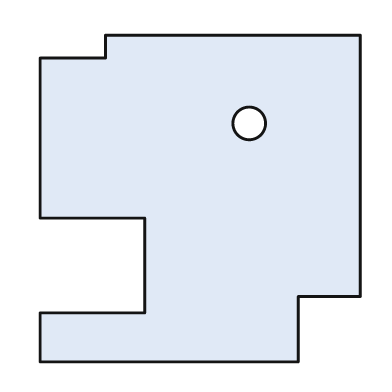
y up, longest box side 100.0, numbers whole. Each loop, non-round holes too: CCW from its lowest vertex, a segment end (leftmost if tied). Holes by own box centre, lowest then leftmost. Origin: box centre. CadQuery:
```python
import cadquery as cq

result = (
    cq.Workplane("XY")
    .moveTo(-49.0, -50.0)
    .lineTo(30.0, -50.0)
    .lineTo(30.0, -30.0)
    .lineTo(49.0, -30.0)
    .lineTo(49.0, 50.0)
    .lineTo(-29.0, 50.0)
    .lineTo(-29.0, 43.0)
    .lineTo(-49.0, 43.0)
    .lineTo(-49.0, -6.0)
    .lineTo(-17.0, -6.0)
    .lineTo(-17.0, -35.0)
    .lineTo(-49.0, -35.0)
    .close()
    .moveTo(15.0, 23.0)
    .circle(5.0)
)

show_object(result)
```